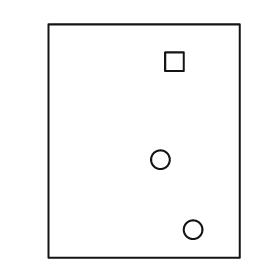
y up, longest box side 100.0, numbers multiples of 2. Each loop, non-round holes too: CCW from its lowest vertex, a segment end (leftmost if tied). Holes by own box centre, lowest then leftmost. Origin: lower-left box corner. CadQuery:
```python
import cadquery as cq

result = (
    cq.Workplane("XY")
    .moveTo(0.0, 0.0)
    .lineTo(82.0, 0.0)
    .lineTo(82.0, 100.0)
    .lineTo(0.0, 100.0)
    .close()
    .moveTo(62.0, 12.0)
    .circle(4.0)
    .moveTo(48.0, 42.0)
    .circle(4.0)
    .moveTo(50.0, 80.0)
    .lineTo(58.0, 80.0)
    .lineTo(58.0, 88.0)
    .lineTo(50.0, 88.0)
    .close()
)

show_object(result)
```